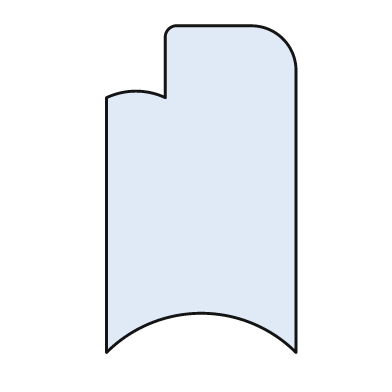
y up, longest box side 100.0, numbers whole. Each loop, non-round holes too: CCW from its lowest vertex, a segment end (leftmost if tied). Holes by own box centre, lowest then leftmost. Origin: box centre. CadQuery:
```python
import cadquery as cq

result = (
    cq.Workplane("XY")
    .moveTo(-29.0, -50.0)
    .threePointArc((0.0, -38.0), (29.0, -50.0))
    .lineTo(29.0, 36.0)
    .threePointArc((25.0, 46.0), (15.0, 50.0))
    .lineTo(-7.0, 50.0)
    .threePointArc((-10.0, 49.0), (-11.0, 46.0))
    .lineTo(-11.0, 28.0)
    .threePointArc((-20.0, 30.0), (-29.0, 28.0))
    .close()
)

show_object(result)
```